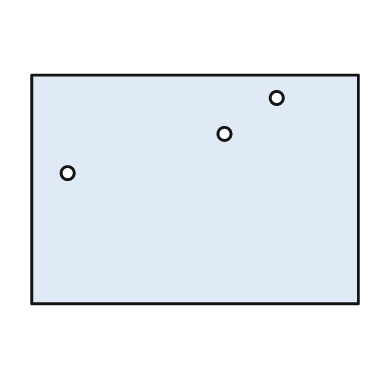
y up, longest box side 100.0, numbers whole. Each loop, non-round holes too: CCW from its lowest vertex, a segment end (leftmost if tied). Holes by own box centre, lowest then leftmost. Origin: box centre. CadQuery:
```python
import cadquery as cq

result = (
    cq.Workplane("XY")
    .moveTo(-50.0, -35.0)
    .lineTo(50.0, -35.0)
    .lineTo(50.0, 35.0)
    .lineTo(-50.0, 35.0)
    .close()
    .moveTo(-39.0, 5.0)
    .circle(2.0)
    .moveTo(9.0, 17.0)
    .circle(2.0)
    .moveTo(25.0, 28.0)
    .circle(2.0)
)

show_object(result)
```